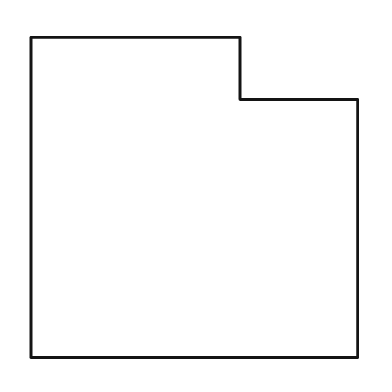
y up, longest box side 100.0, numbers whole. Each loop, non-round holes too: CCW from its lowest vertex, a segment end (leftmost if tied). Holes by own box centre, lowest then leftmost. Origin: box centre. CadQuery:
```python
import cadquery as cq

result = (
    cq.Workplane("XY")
    .moveTo(-50.0, -49.0)
    .lineTo(50.0, -49.0)
    .lineTo(50.0, 30.0)
    .lineTo(14.0, 30.0)
    .lineTo(14.0, 49.0)
    .lineTo(-50.0, 49.0)
    .close()
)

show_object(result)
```